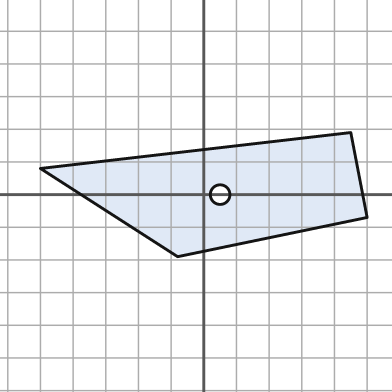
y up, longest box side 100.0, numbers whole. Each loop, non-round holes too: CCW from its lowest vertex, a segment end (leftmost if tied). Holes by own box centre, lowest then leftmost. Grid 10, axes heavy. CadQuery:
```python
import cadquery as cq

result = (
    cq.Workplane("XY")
    .moveTo(-8.0, -19.0)
    .lineTo(50.0, -7.0)
    .lineTo(45.0, 19.0)
    .lineTo(-50.0, 8.0)
    .close()
    .moveTo(5.0, 0.0)
    .circle(3.0)
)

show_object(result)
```